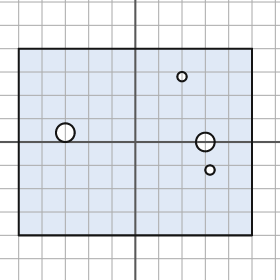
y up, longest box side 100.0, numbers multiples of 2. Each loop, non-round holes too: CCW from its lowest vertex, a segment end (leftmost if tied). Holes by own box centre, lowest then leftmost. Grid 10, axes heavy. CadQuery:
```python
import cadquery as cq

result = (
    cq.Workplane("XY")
    .moveTo(-50.0, -40.0)
    .lineTo(50.0, -40.0)
    .lineTo(50.0, 40.0)
    .lineTo(-50.0, 40.0)
    .close()
    .moveTo(32.0, -12.0)
    .circle(2.0)
    .moveTo(30.0, 0.0)
    .circle(4.0)
    .moveTo(-30.0, 4.0)
    .circle(4.0)
    .moveTo(20.0, 28.0)
    .circle(2.0)
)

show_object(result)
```